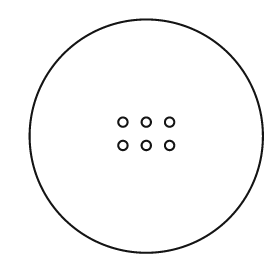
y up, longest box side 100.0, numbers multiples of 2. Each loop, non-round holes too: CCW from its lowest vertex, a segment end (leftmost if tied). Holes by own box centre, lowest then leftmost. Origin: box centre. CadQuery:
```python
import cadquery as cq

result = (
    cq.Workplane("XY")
    .moveTo(0.0, 0.0)
    .circle(50.0)
    .moveTo(-10.0, -4.0)
    .circle(2.0)
    .moveTo(0.0, -4.0)
    .circle(2.0)
    .moveTo(10.0, -4.0)
    .circle(2.0)
    .moveTo(-10.0, 6.0)
    .circle(2.0)
    .moveTo(0.0, 6.0)
    .circle(2.0)
    .moveTo(10.0, 6.0)
    .circle(2.0)
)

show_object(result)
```